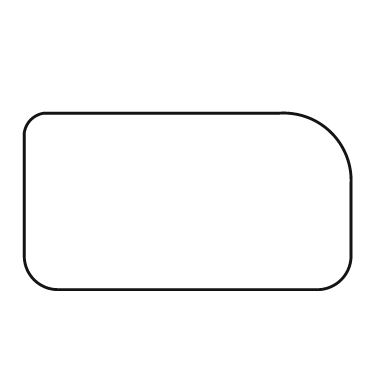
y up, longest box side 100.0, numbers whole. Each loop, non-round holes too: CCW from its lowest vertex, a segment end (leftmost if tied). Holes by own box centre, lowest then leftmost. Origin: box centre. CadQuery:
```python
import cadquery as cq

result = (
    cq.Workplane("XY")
    .moveTo(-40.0, -27.0)
    .lineTo(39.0, -27.0)
    .threePointArc((47.0, -24.0), (50.0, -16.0))
    .lineTo(50.0, 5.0)
    .threePointArc((44.0, 21.0), (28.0, 27.0))
    .lineTo(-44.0, 27.0)
    .threePointArc((-48.0, 25.0), (-50.0, 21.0))
    .lineTo(-50.0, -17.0)
    .threePointArc((-47.0, -24.0), (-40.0, -27.0))
    .close()
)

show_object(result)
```